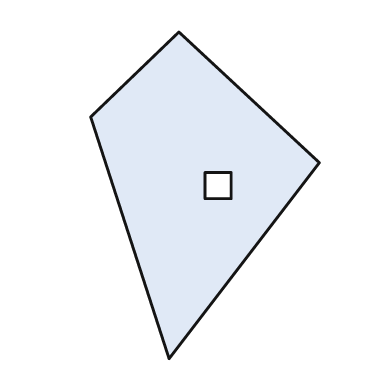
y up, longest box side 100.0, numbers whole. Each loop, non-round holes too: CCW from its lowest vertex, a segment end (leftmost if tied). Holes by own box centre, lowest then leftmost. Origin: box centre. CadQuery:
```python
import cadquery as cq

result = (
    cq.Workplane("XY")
    .moveTo(-11.0, -50.0)
    .lineTo(35.0, 10.0)
    .lineTo(-8.0, 50.0)
    .lineTo(-35.0, 24.0)
    .close()
    .moveTo(0.0, -1.0)
    .lineTo(8.0, -1.0)
    .lineTo(8.0, 7.0)
    .lineTo(0.0, 7.0)
    .close()
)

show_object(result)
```